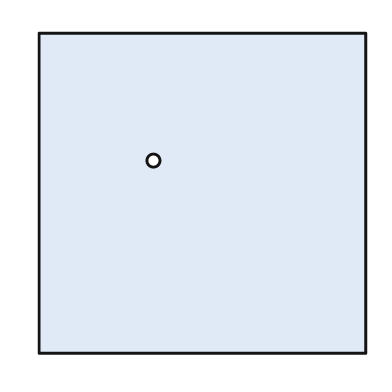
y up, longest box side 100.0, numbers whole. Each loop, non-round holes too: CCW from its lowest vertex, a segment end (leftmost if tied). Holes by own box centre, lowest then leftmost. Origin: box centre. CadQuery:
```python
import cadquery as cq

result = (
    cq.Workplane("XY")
    .moveTo(-50.0, -49.0)
    .lineTo(50.0, -49.0)
    .lineTo(50.0, 49.0)
    .lineTo(-50.0, 49.0)
    .close()
    .moveTo(-15.0, 10.0)
    .circle(2.0)
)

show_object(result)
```